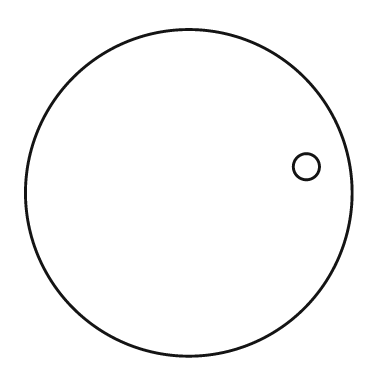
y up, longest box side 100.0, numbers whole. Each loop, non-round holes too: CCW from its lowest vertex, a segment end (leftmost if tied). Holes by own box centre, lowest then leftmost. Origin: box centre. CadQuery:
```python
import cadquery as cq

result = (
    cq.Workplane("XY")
    .moveTo(0.0, 0.0)
    .circle(50.0)
    .moveTo(36.0, 8.0)
    .circle(4.0)
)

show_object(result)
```